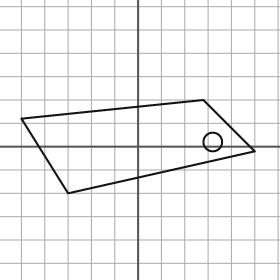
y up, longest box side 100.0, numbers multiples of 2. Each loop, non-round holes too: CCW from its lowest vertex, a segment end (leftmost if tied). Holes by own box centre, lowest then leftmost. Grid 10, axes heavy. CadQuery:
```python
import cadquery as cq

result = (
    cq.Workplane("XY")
    .moveTo(-30.0, -20.0)
    .lineTo(50.0, -2.0)
    .lineTo(28.0, 20.0)
    .lineTo(-50.0, 12.0)
    .close()
    .moveTo(32.0, 2.0)
    .circle(4.0)
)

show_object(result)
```